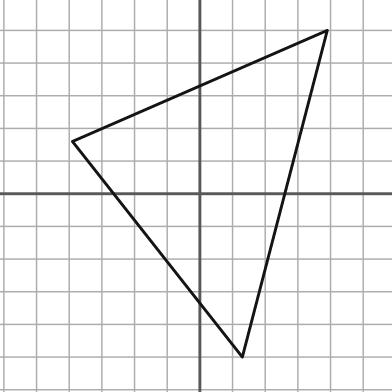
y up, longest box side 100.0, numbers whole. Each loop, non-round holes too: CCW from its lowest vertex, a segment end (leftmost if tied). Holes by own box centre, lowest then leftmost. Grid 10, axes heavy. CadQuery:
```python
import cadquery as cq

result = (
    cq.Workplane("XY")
    .moveTo(13.0, -50.0)
    .lineTo(39.0, 50.0)
    .lineTo(-39.0, 16.0)
    .close()
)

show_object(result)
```